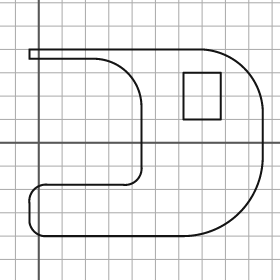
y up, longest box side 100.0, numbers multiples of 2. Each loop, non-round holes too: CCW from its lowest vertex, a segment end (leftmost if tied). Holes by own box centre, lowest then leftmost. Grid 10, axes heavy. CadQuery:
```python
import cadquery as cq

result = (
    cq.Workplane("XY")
    .moveTo(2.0, -40.0)
    .lineTo(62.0, -40.0)
    .threePointArc((86.0, -30.0), (96.0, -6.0))
    .lineTo(96.0, 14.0)
    .threePointArc((88.0, 32.0), (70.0, 40.0))
    .lineTo(-4.0, 40.0)
    .lineTo(-4.0, 36.0)
    .lineTo(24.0, 36.0)
    .threePointArc((38.0, 30.0), (44.0, 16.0))
    .lineTo(44.0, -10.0)
    .threePointArc((42.0, -16.0), (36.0, -18.0))
    .lineTo(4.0, -18.0)
    .threePointArc((-2.0, -20.0), (-4.0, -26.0))
    .lineTo(-4.0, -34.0)
    .threePointArc((-2.0, -38.0), (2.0, -40.0))
    .close()
    .moveTo(62.0, 10.0)
    .lineTo(78.0, 10.0)
    .lineTo(78.0, 30.0)
    .lineTo(62.0, 30.0)
    .close()
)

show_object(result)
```